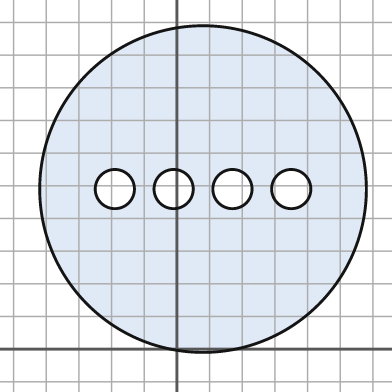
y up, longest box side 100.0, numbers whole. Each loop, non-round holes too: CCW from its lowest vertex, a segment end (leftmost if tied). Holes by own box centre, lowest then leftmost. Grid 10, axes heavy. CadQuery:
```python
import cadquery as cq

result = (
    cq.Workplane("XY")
    .moveTo(8.0, 49.0)
    .circle(50.0)
    .moveTo(-19.0, 49.0)
    .circle(6.0)
    .moveTo(-1.0, 49.0)
    .circle(6.0)
    .moveTo(17.0, 49.0)
    .circle(6.0)
    .moveTo(35.0, 49.0)
    .circle(6.0)
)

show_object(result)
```